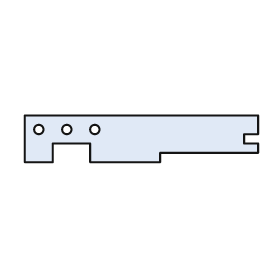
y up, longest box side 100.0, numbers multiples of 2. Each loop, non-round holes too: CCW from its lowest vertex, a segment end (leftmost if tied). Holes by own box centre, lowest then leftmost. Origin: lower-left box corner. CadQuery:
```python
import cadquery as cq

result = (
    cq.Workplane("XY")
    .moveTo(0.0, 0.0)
    .lineTo(12.0, 0.0)
    .lineTo(12.0, 8.0)
    .lineTo(28.0, 8.0)
    .lineTo(28.0, 0.0)
    .lineTo(58.0, 0.0)
    .lineTo(58.0, 4.0)
    .lineTo(100.0, 4.0)
    .lineTo(100.0, 8.0)
    .lineTo(94.0, 8.0)
    .lineTo(94.0, 12.0)
    .lineTo(100.0, 12.0)
    .lineTo(100.0, 20.0)
    .lineTo(0.0, 20.0)
    .close()
    .moveTo(6.0, 14.0)
    .circle(2.0)
    .moveTo(18.0, 14.0)
    .circle(2.0)
    .moveTo(30.0, 14.0)
    .circle(2.0)
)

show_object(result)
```